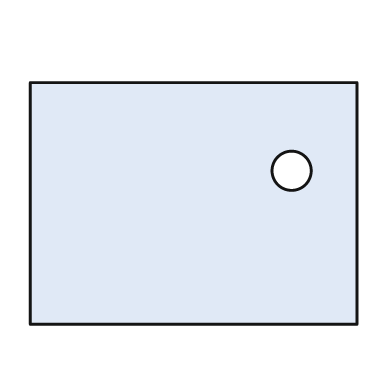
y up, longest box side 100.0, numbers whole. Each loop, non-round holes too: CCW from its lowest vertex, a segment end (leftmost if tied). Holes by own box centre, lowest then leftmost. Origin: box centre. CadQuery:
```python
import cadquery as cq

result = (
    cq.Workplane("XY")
    .moveTo(-50.0, -37.0)
    .lineTo(50.0, -37.0)
    .lineTo(50.0, 37.0)
    .lineTo(-50.0, 37.0)
    .close()
    .moveTo(30.0, 10.0)
    .circle(6.0)
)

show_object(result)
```